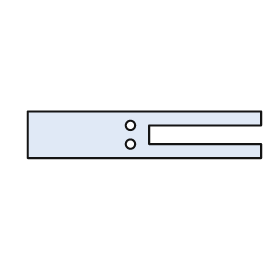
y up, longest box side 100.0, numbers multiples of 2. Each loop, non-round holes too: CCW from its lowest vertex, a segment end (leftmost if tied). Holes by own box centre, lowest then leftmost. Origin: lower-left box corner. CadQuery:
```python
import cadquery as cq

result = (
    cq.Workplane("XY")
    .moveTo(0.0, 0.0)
    .lineTo(100.0, 0.0)
    .lineTo(100.0, 6.0)
    .lineTo(52.0, 6.0)
    .lineTo(52.0, 14.0)
    .lineTo(100.0, 14.0)
    .lineTo(100.0, 20.0)
    .lineTo(0.0, 20.0)
    .close()
    .moveTo(44.0, 6.0)
    .circle(2.0)
    .moveTo(44.0, 14.0)
    .circle(2.0)
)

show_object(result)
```